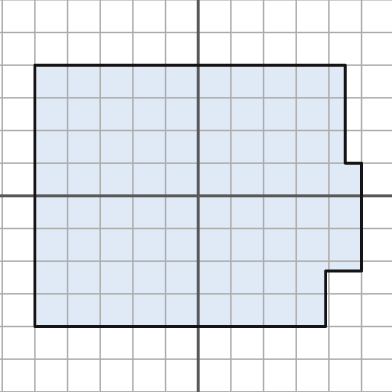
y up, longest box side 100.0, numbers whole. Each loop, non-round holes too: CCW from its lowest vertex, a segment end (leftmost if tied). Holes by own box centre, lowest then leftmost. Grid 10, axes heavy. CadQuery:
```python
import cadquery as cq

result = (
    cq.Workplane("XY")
    .moveTo(-50.0, -40.0)
    .lineTo(39.0, -40.0)
    .lineTo(39.0, -23.0)
    .lineTo(50.0, -23.0)
    .lineTo(50.0, 10.0)
    .lineTo(45.0, 10.0)
    .lineTo(45.0, 40.0)
    .lineTo(-50.0, 40.0)
    .close()
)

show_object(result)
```